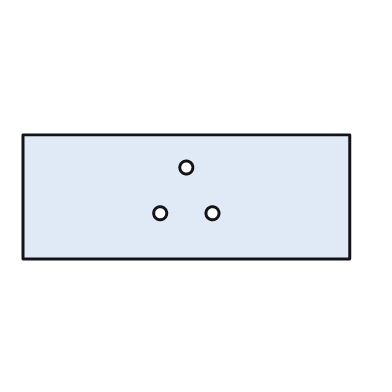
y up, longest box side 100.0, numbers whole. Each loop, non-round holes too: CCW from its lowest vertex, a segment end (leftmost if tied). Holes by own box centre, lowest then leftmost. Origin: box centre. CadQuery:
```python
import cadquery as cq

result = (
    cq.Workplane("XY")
    .moveTo(-50.0, -19.0)
    .lineTo(50.0, -19.0)
    .lineTo(50.0, 19.0)
    .lineTo(-50.0, 19.0)
    .close()
    .moveTo(-8.0, -5.0)
    .circle(2.0)
    .moveTo(8.0, -5.0)
    .circle(2.0)
    .moveTo(0.0, 9.0)
    .circle(2.0)
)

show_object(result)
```